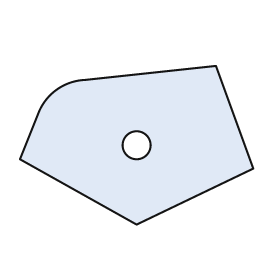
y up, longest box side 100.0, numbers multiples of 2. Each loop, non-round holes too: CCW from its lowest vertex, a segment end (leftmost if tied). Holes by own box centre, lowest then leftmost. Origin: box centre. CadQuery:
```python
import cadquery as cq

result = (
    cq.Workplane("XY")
    .moveTo(0.0, -34.0)
    .lineTo(50.0, -10.0)
    .lineTo(34.0, 34.0)
    .lineTo(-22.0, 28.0)
    .threePointArc((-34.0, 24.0), (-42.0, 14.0))
    .lineTo(-50.0, -6.0)
    .close()
    .moveTo(0.0, 0.0)
    .circle(6.0)
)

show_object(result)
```